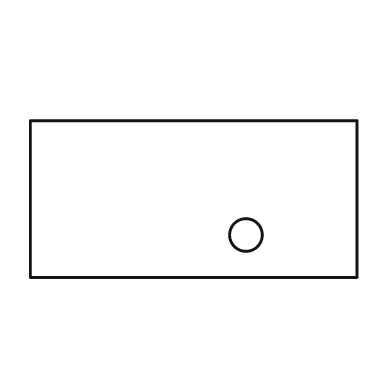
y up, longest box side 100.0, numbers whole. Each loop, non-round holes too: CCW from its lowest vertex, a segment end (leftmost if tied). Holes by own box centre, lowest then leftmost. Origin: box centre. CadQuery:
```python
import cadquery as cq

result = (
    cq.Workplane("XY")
    .moveTo(-50.0, -24.0)
    .lineTo(50.0, -24.0)
    .lineTo(50.0, 24.0)
    .lineTo(-50.0, 24.0)
    .close()
    .moveTo(16.0, -11.0)
    .circle(5.0)
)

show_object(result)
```